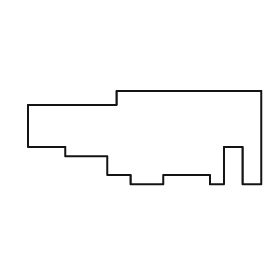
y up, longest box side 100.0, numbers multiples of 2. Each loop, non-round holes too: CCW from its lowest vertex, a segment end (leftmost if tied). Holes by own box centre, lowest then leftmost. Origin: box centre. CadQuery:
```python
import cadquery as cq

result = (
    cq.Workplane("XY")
    .moveTo(-6.0, -20.0)
    .lineTo(8.0, -20.0)
    .lineTo(8.0, -16.0)
    .lineTo(28.0, -16.0)
    .lineTo(28.0, -20.0)
    .lineTo(34.0, -20.0)
    .lineTo(34.0, -4.0)
    .lineTo(42.0, -4.0)
    .lineTo(42.0, -20.0)
    .lineTo(50.0, -20.0)
    .lineTo(50.0, 20.0)
    .lineTo(-12.0, 20.0)
    .lineTo(-12.0, 14.0)
    .lineTo(-50.0, 14.0)
    .lineTo(-50.0, -4.0)
    .lineTo(-34.0, -4.0)
    .lineTo(-34.0, -8.0)
    .lineTo(-16.0, -8.0)
    .lineTo(-16.0, -16.0)
    .lineTo(-6.0, -16.0)
    .close()
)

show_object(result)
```